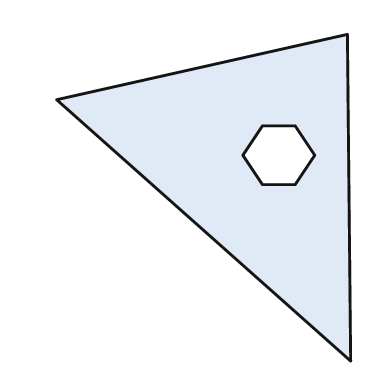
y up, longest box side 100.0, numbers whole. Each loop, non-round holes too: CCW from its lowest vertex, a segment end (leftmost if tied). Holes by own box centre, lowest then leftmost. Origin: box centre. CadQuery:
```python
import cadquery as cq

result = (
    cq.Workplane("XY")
    .moveTo(45.0, -50.0)
    .lineTo(44.0, 50.0)
    .lineTo(-45.0, 30.0)
    .close()
    .moveTo(18.0, 4.0)
    .lineTo(28.0, 4.0)
    .lineTo(34.0, 13.0)
    .lineTo(28.0, 22.0)
    .lineTo(18.0, 22.0)
    .lineTo(12.0, 13.0)
    .close()
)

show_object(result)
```